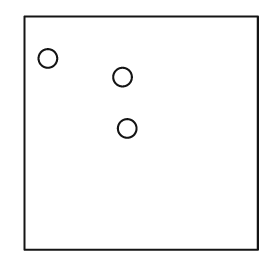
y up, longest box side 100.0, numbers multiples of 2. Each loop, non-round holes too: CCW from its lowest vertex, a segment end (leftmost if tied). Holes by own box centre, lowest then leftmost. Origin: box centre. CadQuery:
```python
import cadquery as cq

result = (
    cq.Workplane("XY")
    .moveTo(-50.0, -50.0)
    .lineTo(50.0, -50.0)
    .lineTo(50.0, 50.0)
    .lineTo(-50.0, 50.0)
    .close()
    .moveTo(-6.0, 2.0)
    .circle(4.0)
    .moveTo(-8.0, 24.0)
    .circle(4.0)
    .moveTo(-40.0, 32.0)
    .circle(4.0)
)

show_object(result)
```